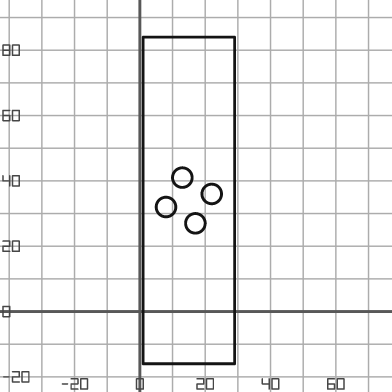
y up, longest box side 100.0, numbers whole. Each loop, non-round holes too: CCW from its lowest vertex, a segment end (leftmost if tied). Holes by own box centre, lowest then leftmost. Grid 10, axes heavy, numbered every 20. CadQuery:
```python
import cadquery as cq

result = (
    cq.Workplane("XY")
    .moveTo(1.0, -16.0)
    .lineTo(29.0, -16.0)
    .lineTo(29.0, 84.0)
    .lineTo(1.0, 84.0)
    .close()
    .moveTo(17.0, 27.0)
    .circle(3.0)
    .moveTo(8.0, 32.0)
    .circle(3.0)
    .moveTo(22.0, 36.0)
    .circle(3.0)
    .moveTo(13.0, 41.0)
    .circle(3.0)
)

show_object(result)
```